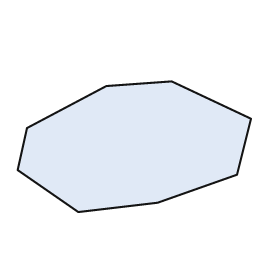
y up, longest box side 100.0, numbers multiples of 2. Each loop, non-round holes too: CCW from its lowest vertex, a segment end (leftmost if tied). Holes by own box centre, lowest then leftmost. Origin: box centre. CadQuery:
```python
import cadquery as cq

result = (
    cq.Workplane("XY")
    .moveTo(-24.0, -28.0)
    .lineTo(10.0, -24.0)
    .lineTo(44.0, -12.0)
    .lineTo(50.0, 12.0)
    .lineTo(16.0, 28.0)
    .lineTo(-12.0, 26.0)
    .lineTo(-46.0, 8.0)
    .lineTo(-50.0, -10.0)
    .close()
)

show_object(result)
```